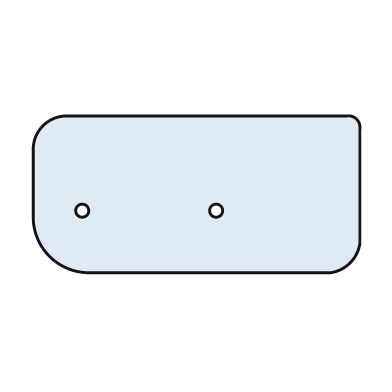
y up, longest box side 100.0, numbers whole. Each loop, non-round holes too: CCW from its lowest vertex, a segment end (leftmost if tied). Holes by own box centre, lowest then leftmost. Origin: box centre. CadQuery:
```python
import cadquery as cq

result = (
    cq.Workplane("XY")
    .moveTo(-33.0, -24.0)
    .lineTo(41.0, -24.0)
    .threePointArc((47.0, -21.0), (50.0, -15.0))
    .lineTo(50.0, 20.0)
    .threePointArc((49.0, 23.0), (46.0, 24.0))
    .lineTo(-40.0, 24.0)
    .threePointArc((-47.0, 21.0), (-50.0, 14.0))
    .lineTo(-50.0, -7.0)
    .threePointArc((-45.0, -19.0), (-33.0, -24.0))
    .close()
    .moveTo(-35.0, -5.0)
    .circle(2.0)
    .moveTo(6.0, -5.0)
    .circle(2.0)
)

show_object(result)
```